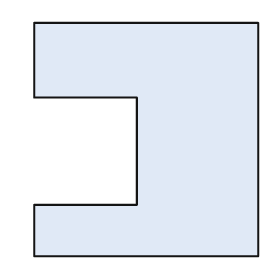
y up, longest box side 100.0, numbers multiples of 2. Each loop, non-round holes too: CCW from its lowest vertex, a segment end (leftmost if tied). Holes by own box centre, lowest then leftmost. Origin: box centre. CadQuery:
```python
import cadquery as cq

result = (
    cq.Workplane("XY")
    .moveTo(-48.0, -50.0)
    .lineTo(48.0, -50.0)
    .lineTo(48.0, 50.0)
    .lineTo(-48.0, 50.0)
    .lineTo(-48.0, 18.0)
    .lineTo(-4.0, 18.0)
    .lineTo(-4.0, -28.0)
    .lineTo(-48.0, -28.0)
    .close()
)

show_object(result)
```